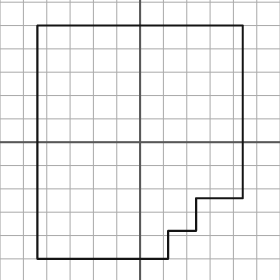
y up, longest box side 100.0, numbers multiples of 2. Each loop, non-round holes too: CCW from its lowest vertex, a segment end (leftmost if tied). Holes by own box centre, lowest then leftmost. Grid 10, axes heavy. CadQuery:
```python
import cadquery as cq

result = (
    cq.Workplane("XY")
    .moveTo(-44.0, -50.0)
    .lineTo(12.0, -50.0)
    .lineTo(12.0, -38.0)
    .lineTo(24.0, -38.0)
    .lineTo(24.0, -24.0)
    .lineTo(44.0, -24.0)
    .lineTo(44.0, 50.0)
    .lineTo(-44.0, 50.0)
    .close()
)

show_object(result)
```